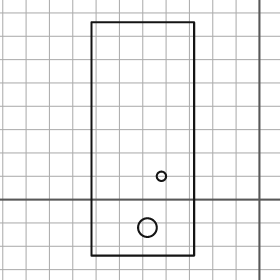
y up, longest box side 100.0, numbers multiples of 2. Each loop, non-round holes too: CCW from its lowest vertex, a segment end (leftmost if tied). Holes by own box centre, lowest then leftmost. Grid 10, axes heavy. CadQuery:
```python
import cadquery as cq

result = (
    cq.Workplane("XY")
    .moveTo(-72.0, -24.0)
    .lineTo(-28.0, -24.0)
    .lineTo(-28.0, 76.0)
    .lineTo(-72.0, 76.0)
    .close()
    .moveTo(-48.0, -12.0)
    .circle(4.0)
    .moveTo(-42.0, 10.0)
    .circle(2.0)
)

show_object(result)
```